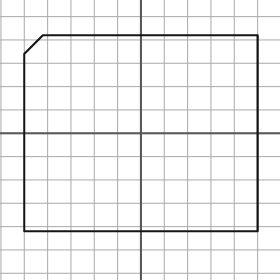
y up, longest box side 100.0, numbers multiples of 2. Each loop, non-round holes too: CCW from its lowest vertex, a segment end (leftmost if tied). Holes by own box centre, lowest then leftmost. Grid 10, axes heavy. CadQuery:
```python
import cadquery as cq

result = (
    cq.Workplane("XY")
    .moveTo(-50.0, -42.0)
    .lineTo(50.0, -42.0)
    .lineTo(50.0, 42.0)
    .lineTo(-42.0, 42.0)
    .lineTo(-50.0, 34.0)
    .close()
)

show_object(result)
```